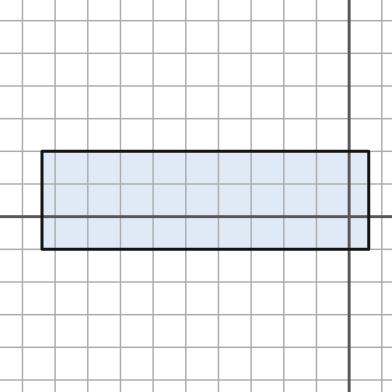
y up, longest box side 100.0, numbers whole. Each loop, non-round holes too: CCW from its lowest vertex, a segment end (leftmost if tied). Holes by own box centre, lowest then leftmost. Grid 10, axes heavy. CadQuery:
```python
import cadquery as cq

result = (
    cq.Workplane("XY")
    .moveTo(-94.0, -10.0)
    .lineTo(6.0, -10.0)
    .lineTo(6.0, 20.0)
    .lineTo(-94.0, 20.0)
    .close()
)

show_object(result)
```